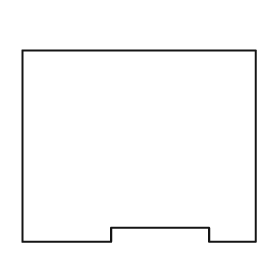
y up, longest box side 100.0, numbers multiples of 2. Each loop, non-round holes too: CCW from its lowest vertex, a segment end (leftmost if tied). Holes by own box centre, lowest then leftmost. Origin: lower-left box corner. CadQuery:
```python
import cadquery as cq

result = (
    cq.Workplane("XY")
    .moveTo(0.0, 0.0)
    .lineTo(38.0, 0.0)
    .lineTo(38.0, 6.0)
    .lineTo(80.0, 6.0)
    .lineTo(80.0, 0.0)
    .lineTo(100.0, 0.0)
    .lineTo(100.0, 82.0)
    .lineTo(0.0, 82.0)
    .close()
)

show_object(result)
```